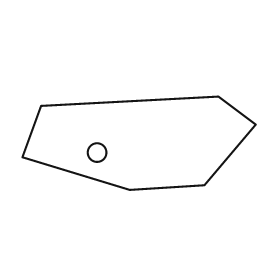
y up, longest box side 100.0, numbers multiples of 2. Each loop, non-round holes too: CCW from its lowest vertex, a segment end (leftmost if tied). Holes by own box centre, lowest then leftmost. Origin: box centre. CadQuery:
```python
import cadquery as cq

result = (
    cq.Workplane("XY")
    .moveTo(-4.0, -20.0)
    .lineTo(28.0, -18.0)
    .lineTo(50.0, 8.0)
    .lineTo(34.0, 20.0)
    .lineTo(-42.0, 16.0)
    .lineTo(-50.0, -6.0)
    .close()
    .moveTo(-18.0, -4.0)
    .circle(4.0)
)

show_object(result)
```